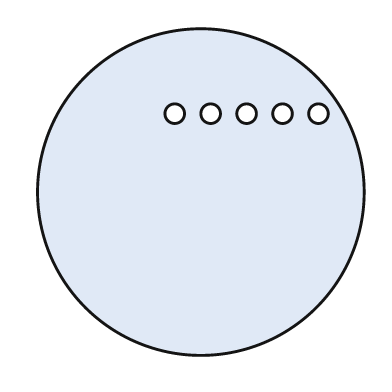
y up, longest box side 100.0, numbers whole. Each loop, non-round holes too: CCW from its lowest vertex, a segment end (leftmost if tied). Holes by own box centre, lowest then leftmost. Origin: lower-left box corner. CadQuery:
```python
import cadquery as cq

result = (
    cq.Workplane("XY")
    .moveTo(50.0, 50.0)
    .circle(50.0)
    .moveTo(42.0, 74.0)
    .circle(3.0)
    .moveTo(53.0, 74.0)
    .circle(3.0)
    .moveTo(64.0, 74.0)
    .circle(3.0)
    .moveTo(75.0, 74.0)
    .circle(3.0)
    .moveTo(86.0, 74.0)
    .circle(3.0)
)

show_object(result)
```